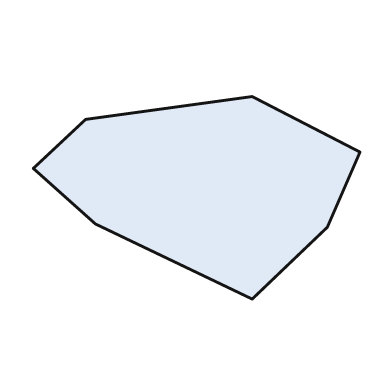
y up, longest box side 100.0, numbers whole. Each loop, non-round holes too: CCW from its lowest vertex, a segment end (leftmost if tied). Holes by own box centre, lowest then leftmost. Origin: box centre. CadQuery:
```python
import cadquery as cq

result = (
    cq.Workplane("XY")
    .moveTo(17.0, -31.0)
    .lineTo(40.0, -9.0)
    .lineTo(50.0, 14.0)
    .lineTo(17.0, 31.0)
    .lineTo(-34.0, 24.0)
    .lineTo(-50.0, 9.0)
    .lineTo(-31.0, -8.0)
    .close()
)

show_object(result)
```